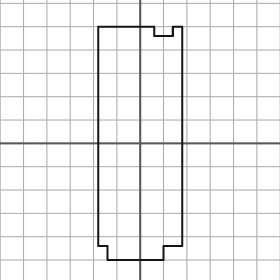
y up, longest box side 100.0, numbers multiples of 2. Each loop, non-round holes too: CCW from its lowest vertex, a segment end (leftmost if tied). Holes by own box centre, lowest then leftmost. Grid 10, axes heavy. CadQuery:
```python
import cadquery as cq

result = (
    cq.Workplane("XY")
    .moveTo(-14.0, -50.0)
    .lineTo(10.0, -50.0)
    .lineTo(10.0, -44.0)
    .lineTo(18.0, -44.0)
    .lineTo(18.0, 50.0)
    .lineTo(14.0, 50.0)
    .lineTo(14.0, 46.0)
    .lineTo(6.0, 46.0)
    .lineTo(6.0, 50.0)
    .lineTo(-18.0, 50.0)
    .lineTo(-18.0, -44.0)
    .lineTo(-14.0, -44.0)
    .close()
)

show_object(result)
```